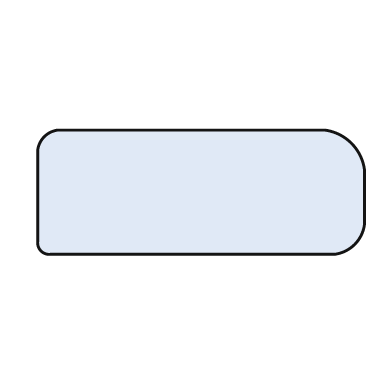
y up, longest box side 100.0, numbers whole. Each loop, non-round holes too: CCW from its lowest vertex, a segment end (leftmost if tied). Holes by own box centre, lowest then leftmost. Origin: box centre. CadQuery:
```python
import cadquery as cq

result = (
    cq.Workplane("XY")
    .moveTo(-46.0, -19.0)
    .lineTo(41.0, -19.0)
    .threePointArc((47.0, -16.0), (50.0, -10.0))
    .lineTo(50.0, 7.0)
    .threePointArc((46.0, 15.0), (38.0, 19.0))
    .lineTo(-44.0, 19.0)
    .threePointArc((-48.0, 17.0), (-50.0, 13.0))
    .lineTo(-50.0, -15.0)
    .threePointArc((-49.0, -18.0), (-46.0, -19.0))
    .close()
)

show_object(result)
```